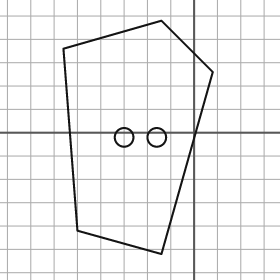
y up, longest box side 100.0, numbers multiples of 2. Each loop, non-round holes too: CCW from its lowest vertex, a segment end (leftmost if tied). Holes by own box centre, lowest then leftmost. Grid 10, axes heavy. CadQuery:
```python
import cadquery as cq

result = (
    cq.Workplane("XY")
    .moveTo(-14.0, -52.0)
    .lineTo(8.0, 26.0)
    .lineTo(-14.0, 48.0)
    .lineTo(-56.0, 36.0)
    .lineTo(-50.0, -42.0)
    .close()
    .moveTo(-30.0, -2.0)
    .circle(4.0)
    .moveTo(-16.0, -2.0)
    .circle(4.0)
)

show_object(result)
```